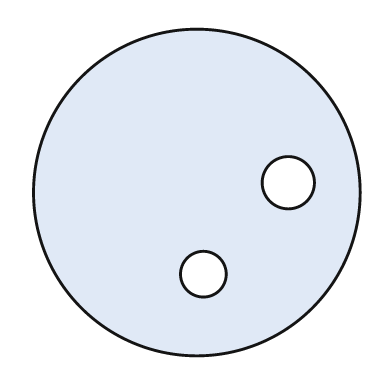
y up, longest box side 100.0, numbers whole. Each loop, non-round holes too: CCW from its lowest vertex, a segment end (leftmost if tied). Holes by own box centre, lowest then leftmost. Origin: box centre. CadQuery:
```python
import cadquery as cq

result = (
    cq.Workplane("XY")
    .moveTo(0.0, 0.0)
    .circle(50.0)
    .moveTo(2.0, -25.0)
    .circle(7.0)
    .moveTo(28.0, 3.0)
    .circle(8.0)
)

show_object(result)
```